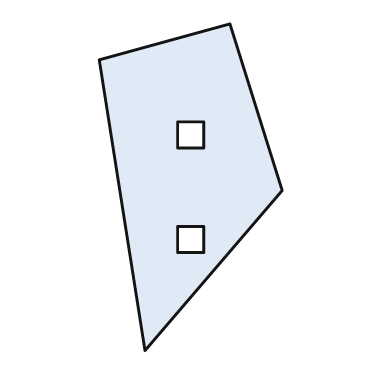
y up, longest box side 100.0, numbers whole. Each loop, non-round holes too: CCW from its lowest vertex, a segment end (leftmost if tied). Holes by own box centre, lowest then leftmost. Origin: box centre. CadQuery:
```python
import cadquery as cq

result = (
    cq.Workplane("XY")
    .moveTo(-14.0, -50.0)
    .lineTo(28.0, -1.0)
    .lineTo(12.0, 50.0)
    .lineTo(-28.0, 39.0)
    .close()
    .moveTo(-4.0, -20.0)
    .lineTo(4.0, -20.0)
    .lineTo(4.0, -12.0)
    .lineTo(-4.0, -12.0)
    .close()
    .moveTo(-4.0, 12.0)
    .lineTo(4.0, 12.0)
    .lineTo(4.0, 20.0)
    .lineTo(-4.0, 20.0)
    .close()
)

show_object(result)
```